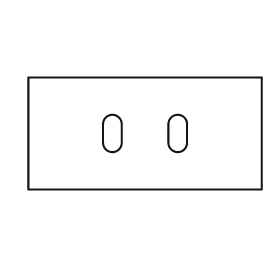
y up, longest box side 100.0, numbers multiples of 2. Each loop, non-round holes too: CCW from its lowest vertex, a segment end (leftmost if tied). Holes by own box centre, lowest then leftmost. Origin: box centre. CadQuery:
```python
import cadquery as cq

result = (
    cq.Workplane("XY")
    .moveTo(-50.0, -24.0)
    .lineTo(50.0, -24.0)
    .lineTo(50.0, 24.0)
    .lineTo(-50.0, 24.0)
    .close()
    .moveTo(-18.0, -4.0)
    .threePointArc((-14.0, -8.0), (-10.0, -4.0))
    .lineTo(-10.0, 4.0)
    .threePointArc((-14.0, 8.0), (-18.0, 4.0))
    .close()
    .moveTo(10.0, -4.0)
    .threePointArc((14.0, -8.0), (18.0, -4.0))
    .lineTo(18.0, 4.0)
    .threePointArc((14.0, 8.0), (10.0, 4.0))
    .close()
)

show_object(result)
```